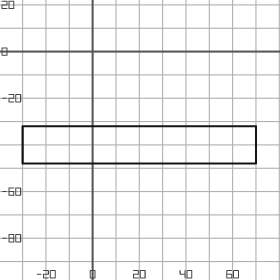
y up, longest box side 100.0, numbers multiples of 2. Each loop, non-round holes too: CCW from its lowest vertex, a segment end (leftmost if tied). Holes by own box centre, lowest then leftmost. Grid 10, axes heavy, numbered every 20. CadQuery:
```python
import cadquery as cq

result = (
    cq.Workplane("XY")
    .moveTo(-30.0, -48.0)
    .lineTo(70.0, -48.0)
    .lineTo(70.0, -32.0)
    .lineTo(-30.0, -32.0)
    .close()
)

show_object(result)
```